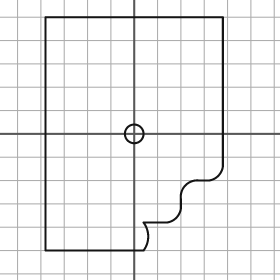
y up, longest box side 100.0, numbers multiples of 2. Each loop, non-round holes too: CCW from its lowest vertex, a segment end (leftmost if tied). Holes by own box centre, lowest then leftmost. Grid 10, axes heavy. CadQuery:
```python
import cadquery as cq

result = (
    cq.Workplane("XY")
    .moveTo(-38.0, -50.0)
    .lineTo(4.0, -50.0)
    .threePointArc((6.0, -44.0), (4.0, -38.0))
    .lineTo(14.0, -38.0)
    .threePointArc((18.0, -36.0), (20.0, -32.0))
    .lineTo(20.0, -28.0)
    .threePointArc((22.0, -22.0), (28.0, -20.0))
    .lineTo(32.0, -20.0)
    .threePointArc((36.0, -18.0), (38.0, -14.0))
    .lineTo(38.0, 50.0)
    .lineTo(-38.0, 50.0)
    .close()
    .moveTo(0.0, 0.0)
    .circle(4.0)
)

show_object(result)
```